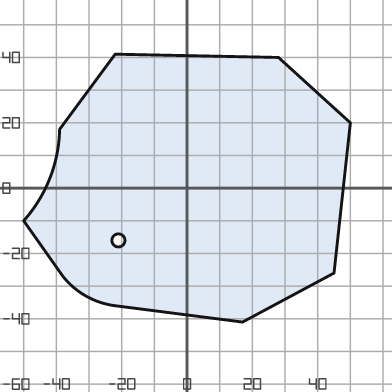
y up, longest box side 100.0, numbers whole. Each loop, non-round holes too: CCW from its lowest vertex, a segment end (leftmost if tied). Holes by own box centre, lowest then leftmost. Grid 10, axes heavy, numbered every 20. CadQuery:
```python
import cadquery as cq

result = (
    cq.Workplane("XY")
    .moveTo(17.0, -41.0)
    .lineTo(45.0, -26.0)
    .lineTo(50.0, 20.0)
    .lineTo(28.0, 40.0)
    .lineTo(-22.0, 41.0)
    .lineTo(-39.0, 18.0)
    .threePointArc((-42.0, 3.0), (-50.0, -10.0))
    .lineTo(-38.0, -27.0)
    .threePointArc((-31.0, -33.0), (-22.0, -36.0))
    .close()
    .moveTo(-21.0, -16.0)
    .circle(2.0)
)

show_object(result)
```